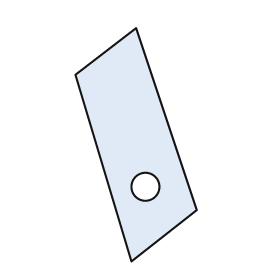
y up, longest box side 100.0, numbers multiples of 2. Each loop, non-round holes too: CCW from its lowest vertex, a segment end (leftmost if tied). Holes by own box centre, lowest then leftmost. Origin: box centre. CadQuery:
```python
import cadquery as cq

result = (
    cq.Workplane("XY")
    .moveTo(-2.0, -50.0)
    .lineTo(26.0, -28.0)
    .lineTo(0.0, 50.0)
    .lineTo(-26.0, 30.0)
    .close()
    .moveTo(4.0, -18.0)
    .circle(6.0)
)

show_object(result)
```